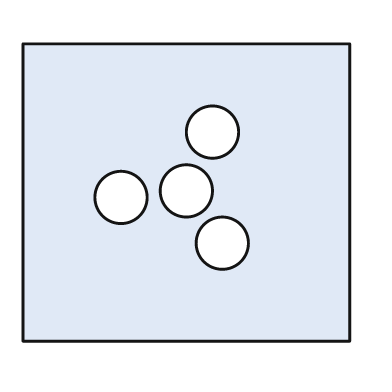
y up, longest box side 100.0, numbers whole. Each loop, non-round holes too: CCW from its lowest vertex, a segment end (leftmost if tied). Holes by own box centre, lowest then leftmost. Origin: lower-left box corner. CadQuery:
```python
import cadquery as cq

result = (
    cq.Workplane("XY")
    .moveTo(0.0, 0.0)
    .lineTo(100.0, 0.0)
    .lineTo(100.0, 91.0)
    .lineTo(0.0, 91.0)
    .close()
    .moveTo(61.0, 30.0)
    .circle(8.0)
    .moveTo(30.0, 44.0)
    .circle(8.0)
    .moveTo(50.0, 46.0)
    .circle(8.0)
    .moveTo(58.0, 64.0)
    .circle(8.0)
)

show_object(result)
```